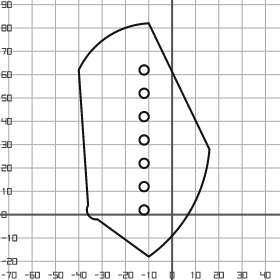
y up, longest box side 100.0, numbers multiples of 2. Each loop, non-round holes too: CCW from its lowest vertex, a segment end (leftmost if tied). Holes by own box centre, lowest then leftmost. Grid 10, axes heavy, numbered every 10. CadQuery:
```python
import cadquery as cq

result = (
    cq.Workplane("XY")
    .moveTo(-10.0, -18.0)
    .threePointArc((8.0, 2.0), (16.0, 28.0))
    .lineTo(-10.0, 82.0)
    .threePointArc((-28.0, 76.0), (-40.0, 62.0))
    .lineTo(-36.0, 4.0)
    .threePointArc((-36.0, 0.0), (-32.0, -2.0))
    .close()
    .moveTo(-12.0, 2.0)
    .circle(2.0)
    .moveTo(-12.0, 12.0)
    .circle(2.0)
    .moveTo(-12.0, 22.0)
    .circle(2.0)
    .moveTo(-12.0, 32.0)
    .circle(2.0)
    .moveTo(-12.0, 42.0)
    .circle(2.0)
    .moveTo(-12.0, 52.0)
    .circle(2.0)
    .moveTo(-12.0, 62.0)
    .circle(2.0)
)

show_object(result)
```